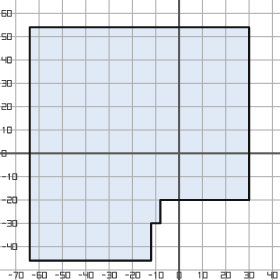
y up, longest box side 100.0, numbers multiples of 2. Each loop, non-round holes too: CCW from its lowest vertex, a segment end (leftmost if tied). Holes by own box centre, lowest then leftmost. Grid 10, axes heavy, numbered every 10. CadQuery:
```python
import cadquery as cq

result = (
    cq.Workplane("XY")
    .moveTo(-64.0, -46.0)
    .lineTo(-12.0, -46.0)
    .lineTo(-12.0, -30.0)
    .lineTo(-8.0, -30.0)
    .lineTo(-8.0, -20.0)
    .lineTo(30.0, -20.0)
    .lineTo(30.0, 54.0)
    .lineTo(-64.0, 54.0)
    .close()
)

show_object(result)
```